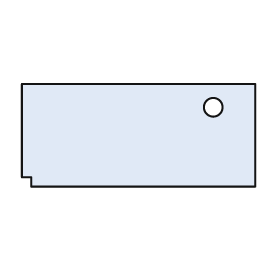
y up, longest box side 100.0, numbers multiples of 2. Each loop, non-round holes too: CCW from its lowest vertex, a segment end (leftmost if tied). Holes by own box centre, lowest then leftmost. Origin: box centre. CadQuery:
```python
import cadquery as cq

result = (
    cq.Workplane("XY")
    .moveTo(-46.0, -22.0)
    .lineTo(50.0, -22.0)
    .lineTo(50.0, 22.0)
    .lineTo(-50.0, 22.0)
    .lineTo(-50.0, -18.0)
    .lineTo(-46.0, -18.0)
    .close()
    .moveTo(32.0, 12.0)
    .circle(4.0)
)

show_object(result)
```